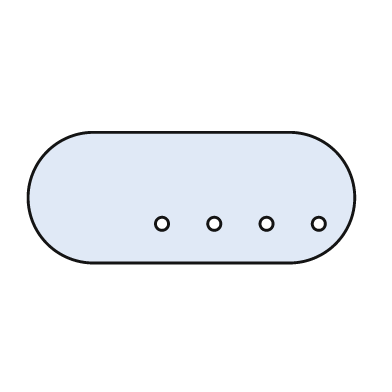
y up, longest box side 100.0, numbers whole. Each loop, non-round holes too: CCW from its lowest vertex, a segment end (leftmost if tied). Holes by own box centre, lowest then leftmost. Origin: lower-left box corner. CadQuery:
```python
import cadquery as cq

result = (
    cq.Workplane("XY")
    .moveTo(20.0, 0.0)
    .lineTo(80.0, 0.0)
    .threePointArc((100.0, 20.0), (80.0, 40.0))
    .lineTo(20.0, 40.0)
    .threePointArc((0.0, 20.0), (20.0, 0.0))
    .close()
    .moveTo(41.0, 12.0)
    .circle(2.0)
    .moveTo(57.0, 12.0)
    .circle(2.0)
    .moveTo(73.0, 12.0)
    .circle(2.0)
    .moveTo(89.0, 12.0)
    .circle(2.0)
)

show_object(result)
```